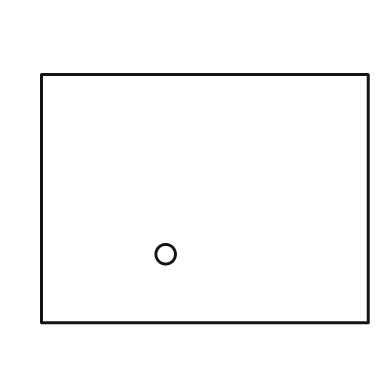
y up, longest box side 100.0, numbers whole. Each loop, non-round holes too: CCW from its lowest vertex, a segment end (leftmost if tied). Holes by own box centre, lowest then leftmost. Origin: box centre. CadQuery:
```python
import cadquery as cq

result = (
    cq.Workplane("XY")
    .moveTo(-50.0, -38.0)
    .lineTo(50.0, -38.0)
    .lineTo(50.0, 38.0)
    .lineTo(-50.0, 38.0)
    .close()
    .moveTo(-12.0, -17.0)
    .circle(3.0)
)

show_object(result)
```